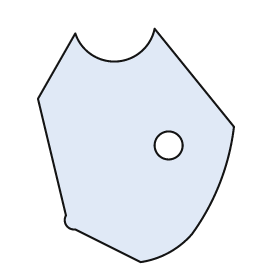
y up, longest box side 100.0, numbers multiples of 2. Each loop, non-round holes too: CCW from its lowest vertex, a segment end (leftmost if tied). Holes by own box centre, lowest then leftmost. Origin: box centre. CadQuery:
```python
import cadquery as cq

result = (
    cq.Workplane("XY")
    .moveTo(2.0, -50.0)
    .threePointArc((14.0, -46.0), (24.0, -38.0))
    .threePointArc((36.0, -16.0), (42.0, 8.0))
    .lineTo(8.0, 50.0)
    .threePointArc((-8.0, 36.0), (-26.0, 48.0))
    .lineTo(-42.0, 20.0)
    .lineTo(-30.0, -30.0)
    .threePointArc((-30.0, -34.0), (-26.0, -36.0))
    .close()
    .moveTo(14.0, 0.0)
    .circle(6.0)
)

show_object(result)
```